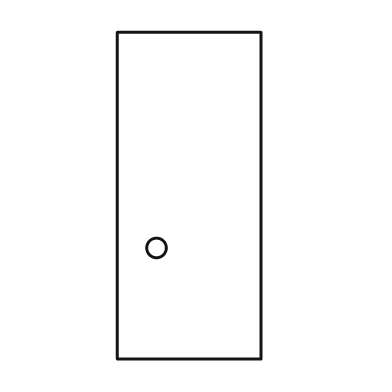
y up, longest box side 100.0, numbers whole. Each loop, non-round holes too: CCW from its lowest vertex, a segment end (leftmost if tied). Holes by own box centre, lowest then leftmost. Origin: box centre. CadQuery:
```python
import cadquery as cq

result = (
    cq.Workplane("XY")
    .moveTo(-22.0, -50.0)
    .lineTo(22.0, -50.0)
    .lineTo(22.0, 50.0)
    .lineTo(-22.0, 50.0)
    .close()
    .moveTo(-10.0, -16.0)
    .circle(3.0)
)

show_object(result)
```